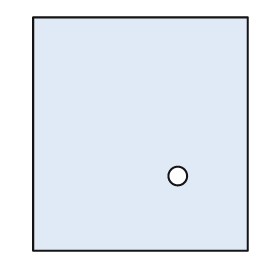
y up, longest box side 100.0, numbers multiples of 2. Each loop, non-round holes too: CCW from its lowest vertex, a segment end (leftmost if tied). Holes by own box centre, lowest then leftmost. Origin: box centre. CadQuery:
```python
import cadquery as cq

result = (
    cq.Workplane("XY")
    .moveTo(-46.0, -50.0)
    .lineTo(46.0, -50.0)
    .lineTo(46.0, 50.0)
    .lineTo(-46.0, 50.0)
    .close()
    .moveTo(16.0, -18.0)
    .circle(4.0)
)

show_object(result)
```